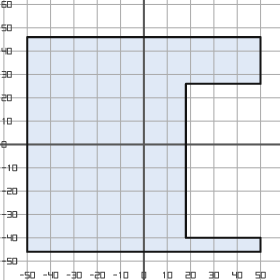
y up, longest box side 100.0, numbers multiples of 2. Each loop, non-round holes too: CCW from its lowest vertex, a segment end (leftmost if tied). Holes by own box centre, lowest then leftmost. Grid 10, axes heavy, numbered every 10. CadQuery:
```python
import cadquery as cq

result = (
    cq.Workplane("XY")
    .moveTo(-50.0, -46.0)
    .lineTo(50.0, -46.0)
    .lineTo(50.0, -40.0)
    .lineTo(18.0, -40.0)
    .lineTo(18.0, 26.0)
    .lineTo(50.0, 26.0)
    .lineTo(50.0, 46.0)
    .lineTo(-50.0, 46.0)
    .close()
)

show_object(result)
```